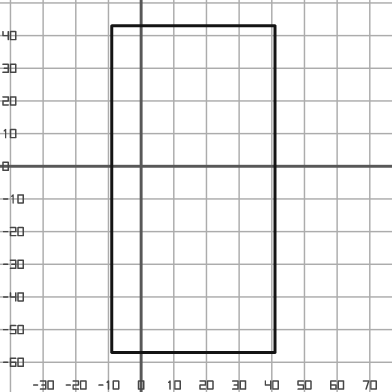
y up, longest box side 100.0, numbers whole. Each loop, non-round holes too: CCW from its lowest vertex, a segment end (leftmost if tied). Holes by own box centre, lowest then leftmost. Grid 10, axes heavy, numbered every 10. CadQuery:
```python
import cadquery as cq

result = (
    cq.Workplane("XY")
    .moveTo(-9.0, -57.0)
    .lineTo(41.0, -57.0)
    .lineTo(41.0, 43.0)
    .lineTo(-9.0, 43.0)
    .close()
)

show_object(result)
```